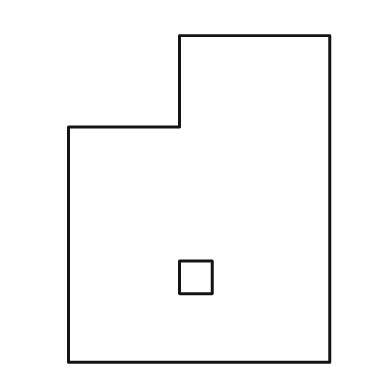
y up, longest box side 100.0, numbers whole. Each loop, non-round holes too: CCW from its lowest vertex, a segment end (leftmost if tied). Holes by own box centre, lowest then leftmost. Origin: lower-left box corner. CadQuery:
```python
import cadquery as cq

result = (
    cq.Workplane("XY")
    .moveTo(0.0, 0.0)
    .lineTo(80.0, 0.0)
    .lineTo(80.0, 100.0)
    .lineTo(34.0, 100.0)
    .lineTo(34.0, 72.0)
    .lineTo(0.0, 72.0)
    .close()
    .moveTo(34.0, 21.0)
    .lineTo(44.0, 21.0)
    .lineTo(44.0, 31.0)
    .lineTo(34.0, 31.0)
    .close()
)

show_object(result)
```